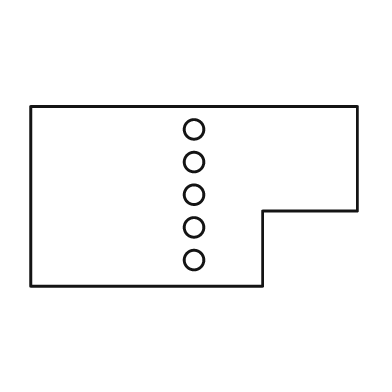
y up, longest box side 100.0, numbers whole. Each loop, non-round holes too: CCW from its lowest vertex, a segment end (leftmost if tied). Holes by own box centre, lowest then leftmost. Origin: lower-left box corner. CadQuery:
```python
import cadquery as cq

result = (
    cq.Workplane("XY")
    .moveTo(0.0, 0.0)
    .lineTo(71.0, 0.0)
    .lineTo(71.0, 23.0)
    .lineTo(100.0, 23.0)
    .lineTo(100.0, 55.0)
    .lineTo(0.0, 55.0)
    .close()
    .moveTo(50.0, 8.0)
    .circle(3.0)
    .moveTo(50.0, 18.0)
    .circle(3.0)
    .moveTo(50.0, 28.0)
    .circle(3.0)
    .moveTo(50.0, 38.0)
    .circle(3.0)
    .moveTo(50.0, 48.0)
    .circle(3.0)
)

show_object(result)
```